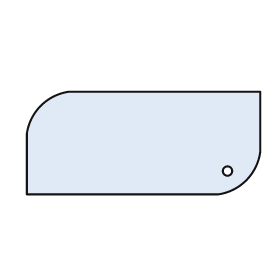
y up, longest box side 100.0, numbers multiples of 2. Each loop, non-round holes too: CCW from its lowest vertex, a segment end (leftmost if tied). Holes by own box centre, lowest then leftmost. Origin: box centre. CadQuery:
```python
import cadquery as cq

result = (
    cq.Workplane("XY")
    .moveTo(-50.0, -22.0)
    .lineTo(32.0, -22.0)
    .threePointArc((44.0, -16.0), (50.0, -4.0))
    .lineTo(50.0, 22.0)
    .lineTo(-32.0, 22.0)
    .threePointArc((-44.0, 16.0), (-50.0, 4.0))
    .close()
    .moveTo(36.0, -12.0)
    .circle(2.0)
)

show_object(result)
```